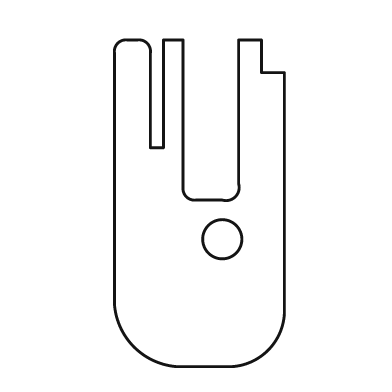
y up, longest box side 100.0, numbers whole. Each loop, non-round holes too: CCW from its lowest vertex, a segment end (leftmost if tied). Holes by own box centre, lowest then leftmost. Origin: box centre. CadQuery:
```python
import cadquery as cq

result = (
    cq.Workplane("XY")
    .moveTo(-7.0, -50.0)
    .lineTo(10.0, -50.0)
    .threePointArc((21.0, -45.0), (26.0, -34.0))
    .lineTo(26.0, 40.0)
    .lineTo(19.0, 40.0)
    .lineTo(19.0, 50.0)
    .lineTo(12.0, 50.0)
    .lineTo(12.0, 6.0)
    .threePointArc((11.0, 2.0), (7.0, 1.0))
    .lineTo(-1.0, 1.0)
    .threePointArc((-4.0, 2.0), (-5.0, 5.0))
    .lineTo(-5.0, 50.0)
    .lineTo(-11.0, 50.0)
    .lineTo(-11.0, 17.0)
    .lineTo(-15.0, 17.0)
    .lineTo(-15.0, 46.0)
    .threePointArc((-16.0, 49.0), (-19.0, 50.0))
    .lineTo(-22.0, 50.0)
    .threePointArc((-25.0, 49.0), (-26.0, 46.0))
    .lineTo(-26.0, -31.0)
    .threePointArc((-20.0, -44.0), (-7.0, -50.0))
    .close()
    .moveTo(7.0, -11.0)
    .circle(6.0)
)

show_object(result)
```